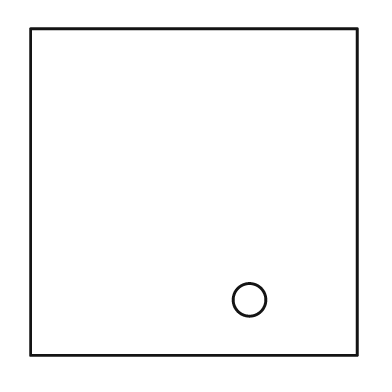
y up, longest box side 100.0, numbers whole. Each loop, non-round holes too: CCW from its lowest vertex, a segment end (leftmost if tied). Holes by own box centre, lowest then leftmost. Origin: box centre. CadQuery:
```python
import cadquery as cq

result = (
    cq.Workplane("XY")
    .moveTo(-50.0, -50.0)
    .lineTo(50.0, -50.0)
    .lineTo(50.0, 50.0)
    .lineTo(-50.0, 50.0)
    .close()
    .moveTo(17.0, -33.0)
    .circle(5.0)
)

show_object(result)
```